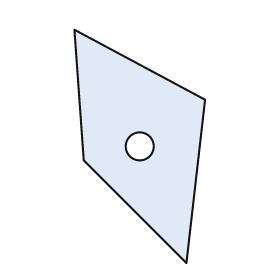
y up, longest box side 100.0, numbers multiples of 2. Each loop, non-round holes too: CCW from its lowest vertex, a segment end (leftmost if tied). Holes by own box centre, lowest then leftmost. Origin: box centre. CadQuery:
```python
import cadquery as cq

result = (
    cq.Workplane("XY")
    .moveTo(20.0, -50.0)
    .lineTo(28.0, 20.0)
    .lineTo(-28.0, 50.0)
    .lineTo(-24.0, -6.0)
    .close()
    .moveTo(0.0, 0.0)
    .circle(6.0)
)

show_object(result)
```